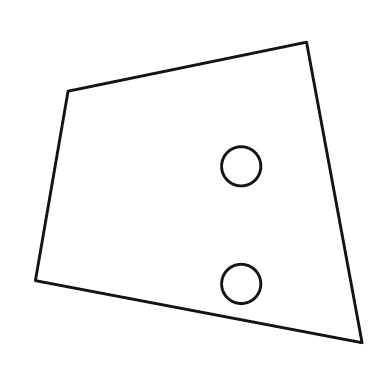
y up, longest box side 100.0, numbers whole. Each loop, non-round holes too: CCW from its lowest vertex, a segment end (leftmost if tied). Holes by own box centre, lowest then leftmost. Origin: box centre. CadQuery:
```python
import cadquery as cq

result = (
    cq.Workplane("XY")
    .moveTo(50.0, -46.0)
    .lineTo(33.0, 46.0)
    .lineTo(-40.0, 31.0)
    .lineTo(-50.0, -27.0)
    .close()
    .moveTo(13.0, -28.0)
    .circle(6.0)
    .moveTo(13.0, 8.0)
    .circle(6.0)
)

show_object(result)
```